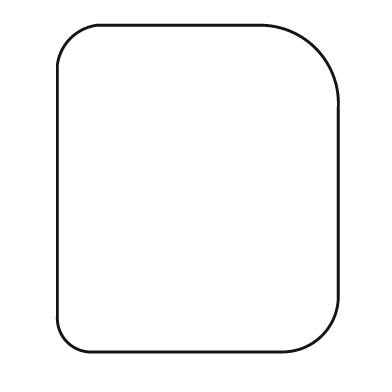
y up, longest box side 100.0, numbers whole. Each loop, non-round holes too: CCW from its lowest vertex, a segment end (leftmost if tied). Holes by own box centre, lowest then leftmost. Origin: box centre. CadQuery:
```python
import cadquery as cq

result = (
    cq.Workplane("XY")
    .moveTo(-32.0, -50.0)
    .lineTo(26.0, -50.0)
    .threePointArc((38.0, -45.0), (43.0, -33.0))
    .lineTo(43.0, 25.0)
    .threePointArc((36.0, 43.0), (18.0, 50.0))
    .lineTo(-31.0, 50.0)
    .threePointArc((-39.0, 46.0), (-43.0, 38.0))
    .lineTo(-43.0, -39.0)
    .threePointArc((-40.0, -47.0), (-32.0, -50.0))
    .close()
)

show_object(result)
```